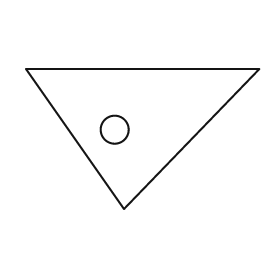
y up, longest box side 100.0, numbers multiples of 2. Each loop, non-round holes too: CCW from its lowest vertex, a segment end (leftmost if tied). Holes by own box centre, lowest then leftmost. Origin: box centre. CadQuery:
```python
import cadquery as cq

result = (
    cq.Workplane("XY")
    .moveTo(-8.0, -30.0)
    .lineTo(50.0, 30.0)
    .lineTo(-50.0, 30.0)
    .close()
    .moveTo(-12.0, 4.0)
    .circle(6.0)
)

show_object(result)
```